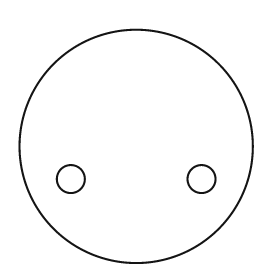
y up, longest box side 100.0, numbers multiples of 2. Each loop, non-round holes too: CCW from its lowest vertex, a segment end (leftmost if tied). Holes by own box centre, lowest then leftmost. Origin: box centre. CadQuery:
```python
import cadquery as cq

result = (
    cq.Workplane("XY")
    .moveTo(0.0, 0.0)
    .circle(50.0)
    .moveTo(-28.0, -14.0)
    .circle(6.0)
    .moveTo(28.0, -14.0)
    .circle(6.0)
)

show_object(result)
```